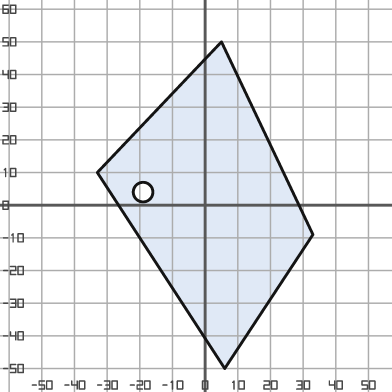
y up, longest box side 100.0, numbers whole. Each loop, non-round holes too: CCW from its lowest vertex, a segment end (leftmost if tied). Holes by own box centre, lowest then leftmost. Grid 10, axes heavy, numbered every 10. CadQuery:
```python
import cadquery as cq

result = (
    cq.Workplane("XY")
    .moveTo(6.0, -50.0)
    .lineTo(33.0, -9.0)
    .lineTo(5.0, 50.0)
    .lineTo(-33.0, 10.0)
    .close()
    .moveTo(-19.0, 4.0)
    .circle(3.0)
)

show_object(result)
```